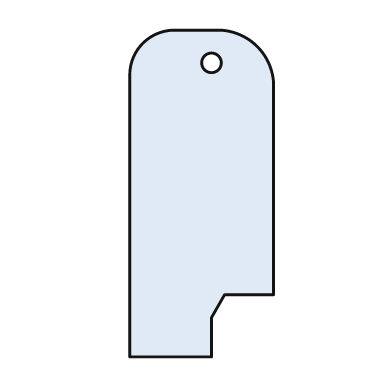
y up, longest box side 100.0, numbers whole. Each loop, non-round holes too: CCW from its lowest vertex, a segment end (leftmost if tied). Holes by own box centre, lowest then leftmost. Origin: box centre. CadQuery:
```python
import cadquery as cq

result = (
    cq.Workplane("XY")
    .moveTo(-22.0, -50.0)
    .lineTo(3.0, -50.0)
    .lineTo(3.0, -38.0)
    .lineTo(7.0, -31.0)
    .lineTo(22.0, -31.0)
    .lineTo(22.0, 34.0)
    .threePointArc((17.0, 45.0), (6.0, 50.0))
    .lineTo(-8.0, 50.0)
    .threePointArc((-18.0, 46.0), (-22.0, 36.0))
    .close()
    .moveTo(3.0, 40.0)
    .circle(3.0)
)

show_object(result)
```